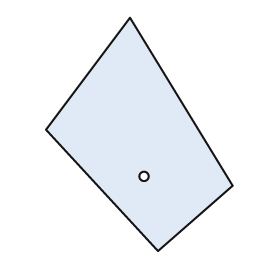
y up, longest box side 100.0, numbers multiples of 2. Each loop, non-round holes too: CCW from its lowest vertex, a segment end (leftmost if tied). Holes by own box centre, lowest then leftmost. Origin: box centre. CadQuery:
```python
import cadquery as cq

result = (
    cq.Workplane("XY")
    .moveTo(8.0, -50.0)
    .lineTo(40.0, -22.0)
    .lineTo(-4.0, 50.0)
    .lineTo(-40.0, 2.0)
    .close()
    .moveTo(2.0, -18.0)
    .circle(2.0)
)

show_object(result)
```